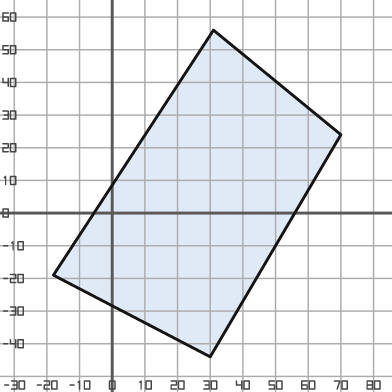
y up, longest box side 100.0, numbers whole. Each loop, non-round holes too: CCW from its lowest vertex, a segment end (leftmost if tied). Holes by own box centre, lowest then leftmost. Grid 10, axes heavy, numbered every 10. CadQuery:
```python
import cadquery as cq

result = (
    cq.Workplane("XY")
    .moveTo(30.0, -44.0)
    .lineTo(70.0, 24.0)
    .lineTo(31.0, 56.0)
    .lineTo(-18.0, -19.0)
    .close()
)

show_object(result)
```